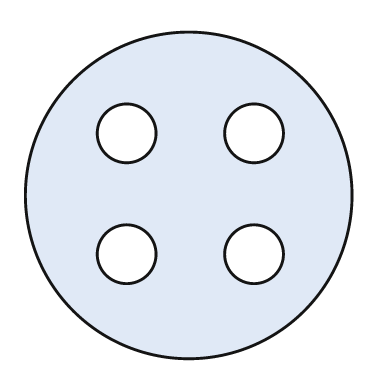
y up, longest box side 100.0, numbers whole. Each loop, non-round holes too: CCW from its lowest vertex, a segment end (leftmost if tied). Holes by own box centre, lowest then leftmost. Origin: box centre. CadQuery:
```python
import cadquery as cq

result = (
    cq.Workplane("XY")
    .moveTo(0.0, 0.0)
    .circle(50.0)
    .moveTo(-19.0, -18.0)
    .circle(9.0)
    .moveTo(20.0, -18.0)
    .circle(9.0)
    .moveTo(-19.0, 19.0)
    .circle(9.0)
    .moveTo(20.0, 19.0)
    .circle(9.0)
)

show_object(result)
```